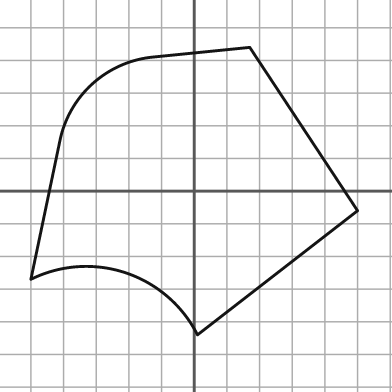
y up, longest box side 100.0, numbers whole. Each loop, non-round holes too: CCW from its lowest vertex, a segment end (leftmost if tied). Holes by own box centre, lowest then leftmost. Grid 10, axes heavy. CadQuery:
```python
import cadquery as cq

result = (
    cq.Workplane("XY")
    .moveTo(1.0, -44.0)
    .lineTo(50.0, -6.0)
    .lineTo(17.0, 44.0)
    .lineTo(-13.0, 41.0)
    .threePointArc((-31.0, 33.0), (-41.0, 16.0))
    .lineTo(-50.0, -27.0)
    .threePointArc((-21.0, -25.0), (1.0, -44.0))
    .close()
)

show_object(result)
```